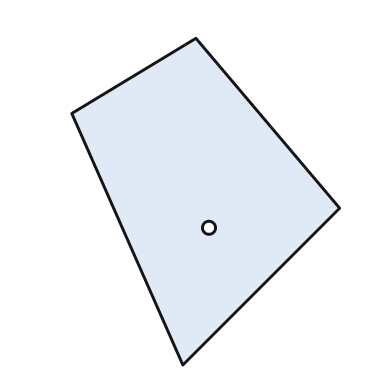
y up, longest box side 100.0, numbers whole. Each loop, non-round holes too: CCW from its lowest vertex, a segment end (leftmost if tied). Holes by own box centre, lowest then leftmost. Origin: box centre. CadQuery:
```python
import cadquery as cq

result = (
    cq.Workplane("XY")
    .moveTo(-7.0, -50.0)
    .lineTo(41.0, -2.0)
    .lineTo(-3.0, 50.0)
    .lineTo(-41.0, 27.0)
    .close()
    .moveTo(1.0, -8.0)
    .circle(2.0)
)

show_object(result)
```